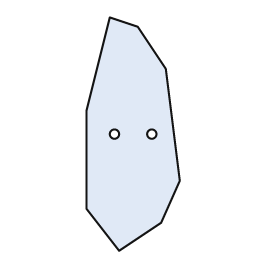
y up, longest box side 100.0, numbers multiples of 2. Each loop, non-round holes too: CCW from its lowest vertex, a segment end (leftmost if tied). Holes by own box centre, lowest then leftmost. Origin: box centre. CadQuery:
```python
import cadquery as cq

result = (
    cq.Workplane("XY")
    .moveTo(-6.0, -50.0)
    .lineTo(12.0, -38.0)
    .lineTo(20.0, -20.0)
    .lineTo(14.0, 28.0)
    .lineTo(2.0, 46.0)
    .lineTo(-10.0, 50.0)
    .lineTo(-20.0, 10.0)
    .lineTo(-20.0, -32.0)
    .close()
    .moveTo(-8.0, 0.0)
    .circle(2.0)
    .moveTo(8.0, 0.0)
    .circle(2.0)
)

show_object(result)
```